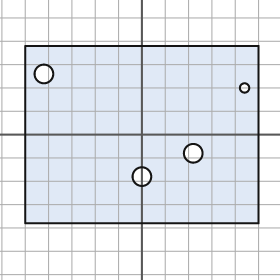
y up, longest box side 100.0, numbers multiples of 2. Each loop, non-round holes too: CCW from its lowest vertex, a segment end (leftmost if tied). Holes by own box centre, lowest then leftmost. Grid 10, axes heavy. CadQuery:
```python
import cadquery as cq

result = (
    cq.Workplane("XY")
    .moveTo(-50.0, -38.0)
    .lineTo(50.0, -38.0)
    .lineTo(50.0, 38.0)
    .lineTo(-50.0, 38.0)
    .close()
    .moveTo(0.0, -18.0)
    .circle(4.0)
    .moveTo(22.0, -8.0)
    .circle(4.0)
    .moveTo(44.0, 20.0)
    .circle(2.0)
    .moveTo(-42.0, 26.0)
    .circle(4.0)
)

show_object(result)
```